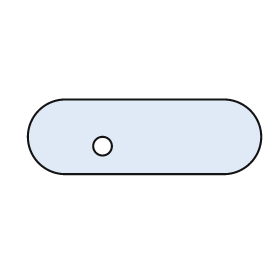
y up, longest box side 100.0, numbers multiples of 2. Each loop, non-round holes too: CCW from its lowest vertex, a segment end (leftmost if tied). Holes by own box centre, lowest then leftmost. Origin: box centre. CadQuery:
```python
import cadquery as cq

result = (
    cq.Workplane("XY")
    .moveTo(-34.0, -16.0)
    .lineTo(34.0, -16.0)
    .threePointArc((50.0, 0.0), (34.0, 16.0))
    .lineTo(-34.0, 16.0)
    .threePointArc((-50.0, 0.0), (-34.0, -16.0))
    .close()
    .moveTo(-18.0, -4.0)
    .circle(4.0)
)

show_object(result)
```